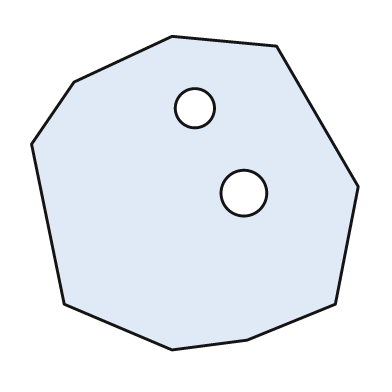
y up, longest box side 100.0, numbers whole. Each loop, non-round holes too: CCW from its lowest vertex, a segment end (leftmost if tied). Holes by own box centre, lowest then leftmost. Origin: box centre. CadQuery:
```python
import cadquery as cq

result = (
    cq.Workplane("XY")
    .moveTo(-7.0, -48.0)
    .lineTo(16.0, -45.0)
    .lineTo(43.0, -34.0)
    .lineTo(50.0, 2.0)
    .lineTo(25.0, 45.0)
    .lineTo(-7.0, 48.0)
    .lineTo(-37.0, 34.0)
    .lineTo(-50.0, 15.0)
    .lineTo(-40.0, -34.0)
    .close()
    .moveTo(15.0, 0.0)
    .circle(7.0)
    .moveTo(0.0, 26.0)
    .circle(6.0)
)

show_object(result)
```